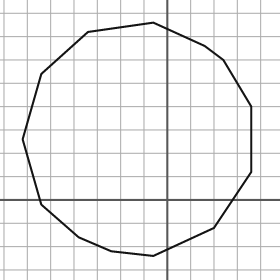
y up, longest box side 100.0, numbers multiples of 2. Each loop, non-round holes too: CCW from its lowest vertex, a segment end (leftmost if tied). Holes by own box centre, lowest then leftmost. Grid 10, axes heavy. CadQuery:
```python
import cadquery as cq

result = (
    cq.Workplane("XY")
    .moveTo(-6.0, -24.0)
    .lineTo(20.0, -12.0)
    .lineTo(36.0, 12.0)
    .lineTo(36.0, 40.0)
    .lineTo(24.0, 60.0)
    .lineTo(16.0, 66.0)
    .lineTo(-6.0, 76.0)
    .lineTo(-34.0, 72.0)
    .lineTo(-54.0, 54.0)
    .lineTo(-62.0, 26.0)
    .lineTo(-54.0, -2.0)
    .lineTo(-38.0, -16.0)
    .lineTo(-24.0, -22.0)
    .close()
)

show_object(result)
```